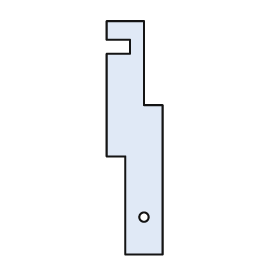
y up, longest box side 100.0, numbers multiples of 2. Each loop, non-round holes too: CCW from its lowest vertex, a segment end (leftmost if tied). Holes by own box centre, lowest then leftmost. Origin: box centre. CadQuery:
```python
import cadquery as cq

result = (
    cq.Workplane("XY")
    .moveTo(-4.0, -50.0)
    .lineTo(12.0, -50.0)
    .lineTo(12.0, 14.0)
    .lineTo(4.0, 14.0)
    .lineTo(4.0, 50.0)
    .lineTo(-12.0, 50.0)
    .lineTo(-12.0, 42.0)
    .lineTo(-2.0, 42.0)
    .lineTo(-2.0, 36.0)
    .lineTo(-12.0, 36.0)
    .lineTo(-12.0, -8.0)
    .lineTo(-4.0, -8.0)
    .close()
    .moveTo(4.0, -34.0)
    .circle(2.0)
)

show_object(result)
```